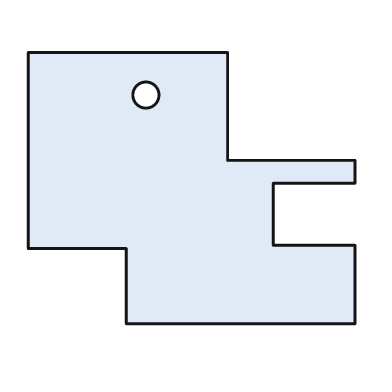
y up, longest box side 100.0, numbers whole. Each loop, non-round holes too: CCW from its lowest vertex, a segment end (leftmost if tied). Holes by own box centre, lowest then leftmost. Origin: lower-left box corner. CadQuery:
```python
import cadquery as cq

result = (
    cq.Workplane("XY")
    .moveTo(30.0, 0.0)
    .lineTo(100.0, 0.0)
    .lineTo(100.0, 24.0)
    .lineTo(75.0, 24.0)
    .lineTo(75.0, 43.0)
    .lineTo(100.0, 43.0)
    .lineTo(100.0, 50.0)
    .lineTo(61.0, 50.0)
    .lineTo(61.0, 83.0)
    .lineTo(0.0, 83.0)
    .lineTo(0.0, 23.0)
    .lineTo(30.0, 23.0)
    .close()
    .moveTo(36.0, 70.0)
    .circle(4.0)
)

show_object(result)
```